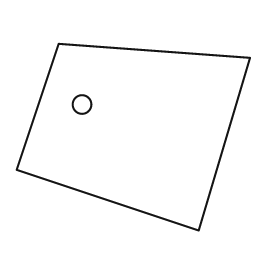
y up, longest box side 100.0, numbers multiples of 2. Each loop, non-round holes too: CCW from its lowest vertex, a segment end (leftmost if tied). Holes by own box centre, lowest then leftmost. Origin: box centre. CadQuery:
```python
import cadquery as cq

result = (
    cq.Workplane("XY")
    .moveTo(28.0, -40.0)
    .lineTo(50.0, 34.0)
    .lineTo(-32.0, 40.0)
    .lineTo(-50.0, -14.0)
    .close()
    .moveTo(-22.0, 14.0)
    .circle(4.0)
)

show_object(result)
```